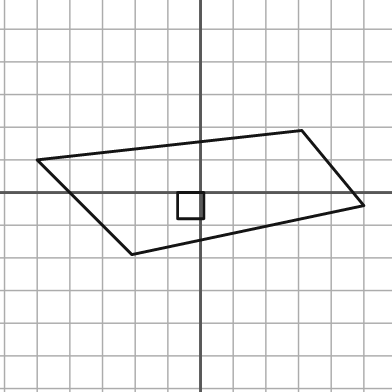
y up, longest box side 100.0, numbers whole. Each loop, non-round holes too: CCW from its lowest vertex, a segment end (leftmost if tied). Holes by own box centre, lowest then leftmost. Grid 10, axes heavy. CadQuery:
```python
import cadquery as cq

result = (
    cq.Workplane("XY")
    .moveTo(-21.0, -19.0)
    .lineTo(50.0, -4.0)
    .lineTo(31.0, 19.0)
    .lineTo(-50.0, 10.0)
    .close()
    .moveTo(-7.0, -8.0)
    .lineTo(1.0, -8.0)
    .lineTo(1.0, 0.0)
    .lineTo(-7.0, 0.0)
    .close()
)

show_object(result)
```